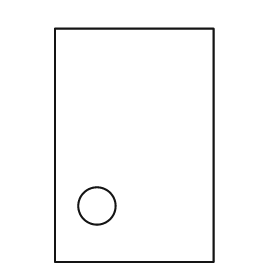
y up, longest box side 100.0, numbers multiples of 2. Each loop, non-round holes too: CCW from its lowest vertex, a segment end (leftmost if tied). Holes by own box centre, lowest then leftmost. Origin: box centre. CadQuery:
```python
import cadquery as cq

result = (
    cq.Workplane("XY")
    .moveTo(-34.0, -50.0)
    .lineTo(34.0, -50.0)
    .lineTo(34.0, 50.0)
    .lineTo(-34.0, 50.0)
    .close()
    .moveTo(-16.0, -26.0)
    .circle(8.0)
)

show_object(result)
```